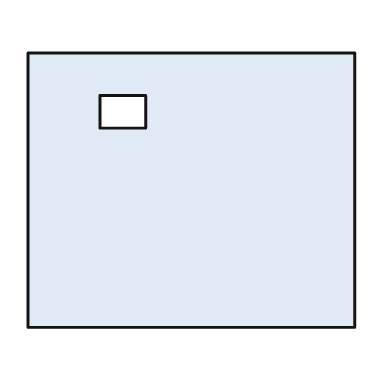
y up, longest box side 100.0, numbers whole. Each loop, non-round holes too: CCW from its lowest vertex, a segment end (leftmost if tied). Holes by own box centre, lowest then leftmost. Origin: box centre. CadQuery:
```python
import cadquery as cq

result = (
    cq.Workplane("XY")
    .moveTo(-50.0, -42.0)
    .lineTo(50.0, -42.0)
    .lineTo(50.0, 42.0)
    .lineTo(-50.0, 42.0)
    .close()
    .moveTo(-28.0, 19.0)
    .lineTo(-14.0, 19.0)
    .lineTo(-14.0, 29.0)
    .lineTo(-28.0, 29.0)
    .close()
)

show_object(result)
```